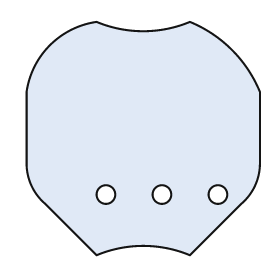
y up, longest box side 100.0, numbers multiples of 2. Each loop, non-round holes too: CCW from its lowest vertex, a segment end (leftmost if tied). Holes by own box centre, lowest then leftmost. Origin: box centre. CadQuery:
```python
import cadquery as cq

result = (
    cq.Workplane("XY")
    .moveTo(-20.0, -50.0)
    .threePointArc((0.0, -46.0), (20.0, -50.0))
    .lineTo(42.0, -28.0)
    .threePointArc((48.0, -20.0), (50.0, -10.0))
    .lineTo(50.0, 20.0)
    .threePointArc((38.0, 38.0), (20.0, 50.0))
    .threePointArc((0.0, 46.0), (-20.0, 50.0))
    .threePointArc((-40.0, 40.0), (-50.0, 20.0))
    .lineTo(-50.0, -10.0)
    .threePointArc((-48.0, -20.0), (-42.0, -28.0))
    .close()
    .moveTo(-16.0, -24.0)
    .circle(4.0)
    .moveTo(8.0, -24.0)
    .circle(4.0)
    .moveTo(32.0, -24.0)
    .circle(4.0)
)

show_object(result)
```